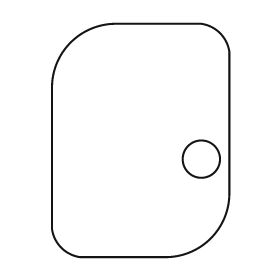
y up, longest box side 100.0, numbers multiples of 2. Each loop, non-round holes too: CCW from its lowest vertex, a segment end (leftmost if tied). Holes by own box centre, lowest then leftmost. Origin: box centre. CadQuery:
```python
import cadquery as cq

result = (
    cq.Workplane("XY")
    .moveTo(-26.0, -50.0)
    .lineTo(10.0, -50.0)
    .threePointArc((30.0, -42.0), (38.0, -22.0))
    .lineTo(38.0, 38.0)
    .threePointArc((34.0, 46.0), (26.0, 50.0))
    .lineTo(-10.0, 50.0)
    .threePointArc((-30.0, 42.0), (-38.0, 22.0))
    .lineTo(-38.0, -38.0)
    .threePointArc((-34.0, -46.0), (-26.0, -50.0))
    .close()
    .moveTo(26.0, -8.0)
    .circle(8.0)
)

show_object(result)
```